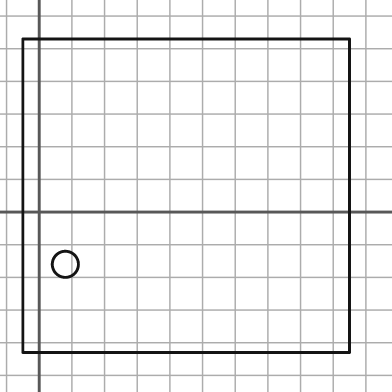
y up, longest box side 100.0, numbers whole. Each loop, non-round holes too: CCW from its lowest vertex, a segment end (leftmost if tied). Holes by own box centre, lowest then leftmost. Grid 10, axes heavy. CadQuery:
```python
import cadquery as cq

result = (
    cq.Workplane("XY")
    .moveTo(-5.0, -43.0)
    .lineTo(95.0, -43.0)
    .lineTo(95.0, 53.0)
    .lineTo(-5.0, 53.0)
    .close()
    .moveTo(8.0, -16.0)
    .circle(4.0)
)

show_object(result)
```